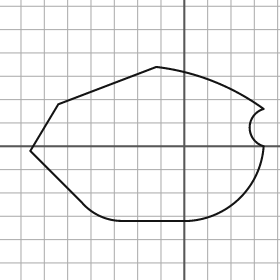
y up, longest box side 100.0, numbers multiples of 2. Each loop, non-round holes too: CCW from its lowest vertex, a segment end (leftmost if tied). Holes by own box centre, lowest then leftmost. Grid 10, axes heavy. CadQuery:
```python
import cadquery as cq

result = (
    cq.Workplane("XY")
    .moveTo(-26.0, -32.0)
    .lineTo(2.0, -32.0)
    .threePointArc((24.0, -22.0), (34.0, 0.0))
    .threePointArc((28.0, 8.0), (34.0, 16.0))
    .threePointArc((12.0, 28.0), (-12.0, 34.0))
    .lineTo(-54.0, 18.0)
    .lineTo(-66.0, -2.0)
    .lineTo(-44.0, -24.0)
    .threePointArc((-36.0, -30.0), (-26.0, -32.0))
    .close()
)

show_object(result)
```